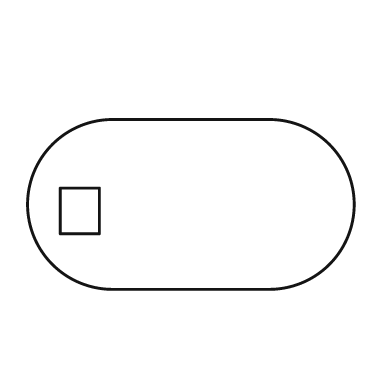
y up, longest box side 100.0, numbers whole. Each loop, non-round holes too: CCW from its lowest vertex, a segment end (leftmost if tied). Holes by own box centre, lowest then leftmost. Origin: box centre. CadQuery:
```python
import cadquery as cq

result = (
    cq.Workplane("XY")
    .moveTo(-24.0, -26.0)
    .lineTo(24.0, -26.0)
    .threePointArc((50.0, 0.0), (24.0, 26.0))
    .lineTo(-24.0, 26.0)
    .threePointArc((-50.0, 0.0), (-24.0, -26.0))
    .close()
    .moveTo(-40.0, -9.0)
    .lineTo(-28.0, -9.0)
    .lineTo(-28.0, 5.0)
    .lineTo(-40.0, 5.0)
    .close()
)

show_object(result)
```